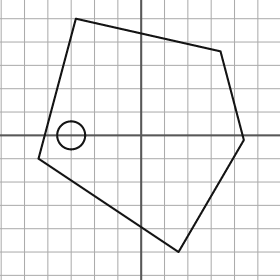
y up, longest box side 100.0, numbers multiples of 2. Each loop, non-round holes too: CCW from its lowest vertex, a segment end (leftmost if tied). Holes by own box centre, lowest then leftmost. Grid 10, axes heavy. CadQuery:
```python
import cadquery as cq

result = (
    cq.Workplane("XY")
    .moveTo(16.0, -50.0)
    .lineTo(44.0, -2.0)
    .lineTo(34.0, 36.0)
    .lineTo(-28.0, 50.0)
    .lineTo(-44.0, -10.0)
    .close()
    .moveTo(-30.0, 0.0)
    .circle(6.0)
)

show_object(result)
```